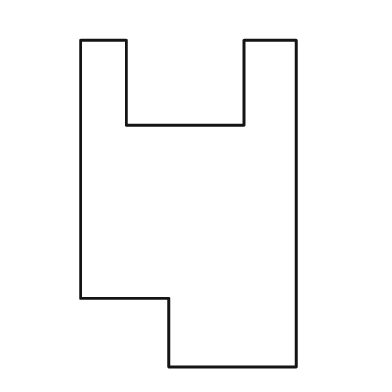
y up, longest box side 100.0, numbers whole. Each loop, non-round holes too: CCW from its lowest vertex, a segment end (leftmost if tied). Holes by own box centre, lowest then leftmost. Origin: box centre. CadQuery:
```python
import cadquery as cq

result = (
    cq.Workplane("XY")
    .moveTo(-6.0, -50.0)
    .lineTo(33.0, -50.0)
    .lineTo(33.0, 50.0)
    .lineTo(17.0, 50.0)
    .lineTo(17.0, 24.0)
    .lineTo(-19.0, 24.0)
    .lineTo(-19.0, 50.0)
    .lineTo(-33.0, 50.0)
    .lineTo(-33.0, -29.0)
    .lineTo(-6.0, -29.0)
    .close()
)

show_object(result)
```